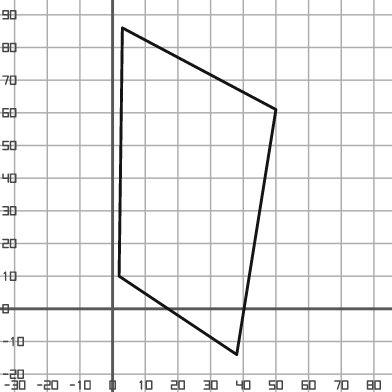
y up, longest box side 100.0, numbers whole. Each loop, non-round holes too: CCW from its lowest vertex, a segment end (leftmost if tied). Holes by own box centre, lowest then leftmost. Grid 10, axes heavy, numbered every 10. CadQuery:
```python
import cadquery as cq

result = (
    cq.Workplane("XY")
    .moveTo(38.0, -14.0)
    .lineTo(50.0, 61.0)
    .lineTo(3.0, 86.0)
    .lineTo(2.0, 10.0)
    .close()
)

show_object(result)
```